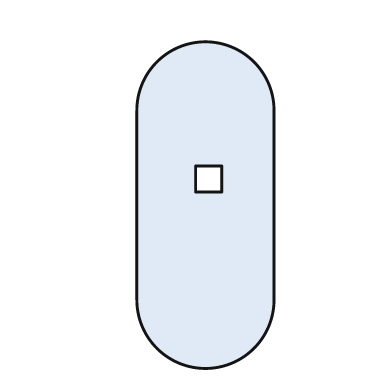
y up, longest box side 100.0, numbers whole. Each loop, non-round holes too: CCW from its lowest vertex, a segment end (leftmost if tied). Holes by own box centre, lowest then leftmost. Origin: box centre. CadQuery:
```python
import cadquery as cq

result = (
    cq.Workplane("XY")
    .moveTo(-21.0, -29.0)
    .threePointArc((0.0, -50.0), (21.0, -29.0))
    .lineTo(21.0, 29.0)
    .threePointArc((0.0, 50.0), (-21.0, 29.0))
    .close()
    .moveTo(-3.0, 4.0)
    .lineTo(5.0, 4.0)
    .lineTo(5.0, 12.0)
    .lineTo(-3.0, 12.0)
    .close()
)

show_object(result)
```